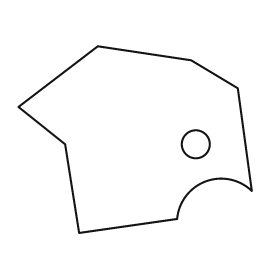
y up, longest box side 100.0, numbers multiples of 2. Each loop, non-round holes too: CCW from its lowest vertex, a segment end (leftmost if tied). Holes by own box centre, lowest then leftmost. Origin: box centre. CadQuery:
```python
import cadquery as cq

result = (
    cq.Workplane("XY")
    .moveTo(-24.0, -40.0)
    .lineTo(18.0, -34.0)
    .threePointArc((30.0, -18.0), (50.0, -22.0))
    .lineTo(44.0, 22.0)
    .lineTo(24.0, 34.0)
    .lineTo(-16.0, 40.0)
    .lineTo(-50.0, 14.0)
    .lineTo(-30.0, -2.0)
    .close()
    .moveTo(26.0, -2.0)
    .circle(6.0)
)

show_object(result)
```